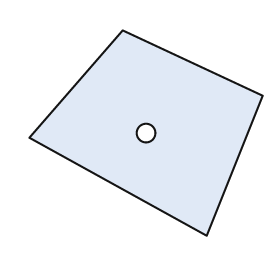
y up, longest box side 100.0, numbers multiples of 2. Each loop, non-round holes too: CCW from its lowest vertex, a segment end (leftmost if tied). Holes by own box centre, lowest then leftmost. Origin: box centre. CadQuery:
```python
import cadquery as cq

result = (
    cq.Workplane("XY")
    .moveTo(26.0, -44.0)
    .lineTo(50.0, 16.0)
    .lineTo(-10.0, 44.0)
    .lineTo(-50.0, -2.0)
    .close()
    .moveTo(0.0, 0.0)
    .circle(4.0)
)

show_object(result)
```